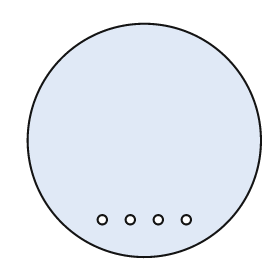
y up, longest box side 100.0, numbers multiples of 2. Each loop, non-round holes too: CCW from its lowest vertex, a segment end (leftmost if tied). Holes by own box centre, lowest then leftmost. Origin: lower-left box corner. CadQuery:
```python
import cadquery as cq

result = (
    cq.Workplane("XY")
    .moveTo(50.0, 50.0)
    .circle(50.0)
    .moveTo(32.0, 16.0)
    .circle(2.0)
    .moveTo(44.0, 16.0)
    .circle(2.0)
    .moveTo(56.0, 16.0)
    .circle(2.0)
    .moveTo(68.0, 16.0)
    .circle(2.0)
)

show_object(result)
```